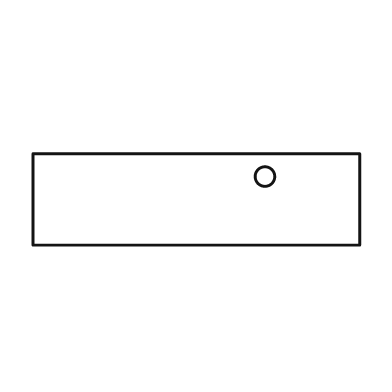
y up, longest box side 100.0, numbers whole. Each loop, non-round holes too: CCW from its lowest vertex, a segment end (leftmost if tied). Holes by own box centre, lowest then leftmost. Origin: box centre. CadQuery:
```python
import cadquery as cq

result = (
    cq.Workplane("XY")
    .moveTo(-50.0, -14.0)
    .lineTo(50.0, -14.0)
    .lineTo(50.0, 14.0)
    .lineTo(-50.0, 14.0)
    .close()
    .moveTo(21.0, 7.0)
    .circle(3.0)
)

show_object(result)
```